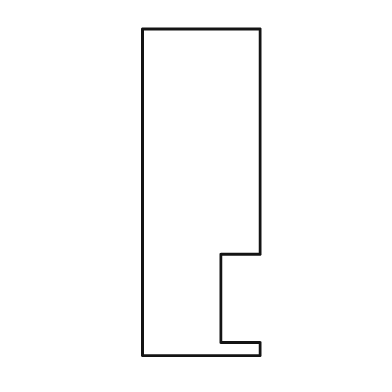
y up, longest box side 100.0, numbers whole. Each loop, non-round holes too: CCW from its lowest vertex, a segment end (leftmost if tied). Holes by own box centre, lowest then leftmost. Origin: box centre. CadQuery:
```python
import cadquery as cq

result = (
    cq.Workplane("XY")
    .moveTo(-18.0, -50.0)
    .lineTo(18.0, -50.0)
    .lineTo(18.0, -46.0)
    .lineTo(6.0, -46.0)
    .lineTo(6.0, -19.0)
    .lineTo(18.0, -19.0)
    .lineTo(18.0, 50.0)
    .lineTo(-18.0, 50.0)
    .close()
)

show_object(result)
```